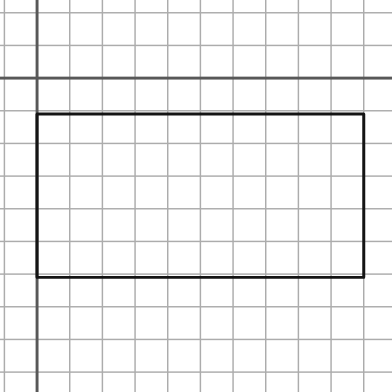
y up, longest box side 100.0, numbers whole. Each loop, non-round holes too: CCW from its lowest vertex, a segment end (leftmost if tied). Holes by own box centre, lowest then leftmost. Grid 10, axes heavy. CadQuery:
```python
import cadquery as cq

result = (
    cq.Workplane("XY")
    .moveTo(0.0, -61.0)
    .lineTo(100.0, -61.0)
    .lineTo(100.0, -11.0)
    .lineTo(0.0, -11.0)
    .close()
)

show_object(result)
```